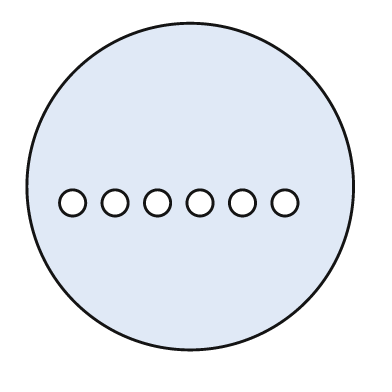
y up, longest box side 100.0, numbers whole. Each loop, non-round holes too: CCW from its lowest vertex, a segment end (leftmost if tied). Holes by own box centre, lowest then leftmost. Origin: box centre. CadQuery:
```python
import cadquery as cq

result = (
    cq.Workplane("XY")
    .moveTo(0.0, 0.0)
    .circle(50.0)
    .moveTo(-36.0, -5.0)
    .circle(4.0)
    .moveTo(-23.0, -5.0)
    .circle(4.0)
    .moveTo(-10.0, -5.0)
    .circle(4.0)
    .moveTo(3.0, -5.0)
    .circle(4.0)
    .moveTo(16.0, -5.0)
    .circle(4.0)
    .moveTo(29.0, -5.0)
    .circle(4.0)
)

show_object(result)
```